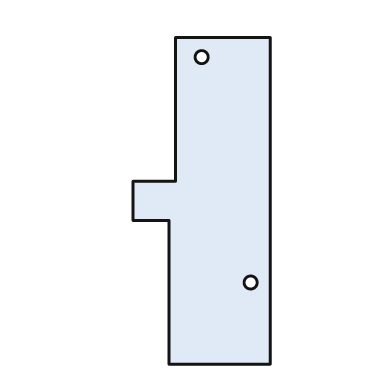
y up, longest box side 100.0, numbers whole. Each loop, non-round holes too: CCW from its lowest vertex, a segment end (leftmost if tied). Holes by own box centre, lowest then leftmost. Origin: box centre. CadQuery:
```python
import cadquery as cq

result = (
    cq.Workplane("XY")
    .moveTo(-10.0, -50.0)
    .lineTo(21.0, -50.0)
    .lineTo(21.0, 50.0)
    .lineTo(-8.0, 50.0)
    .lineTo(-8.0, 6.0)
    .lineTo(-21.0, 6.0)
    .lineTo(-21.0, -6.0)
    .lineTo(-10.0, -6.0)
    .close()
    .moveTo(15.0, -25.0)
    .circle(2.0)
    .moveTo(0.0, 44.0)
    .circle(2.0)
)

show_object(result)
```